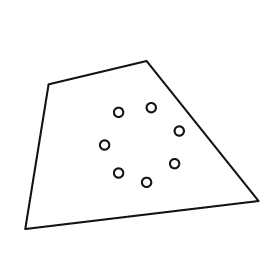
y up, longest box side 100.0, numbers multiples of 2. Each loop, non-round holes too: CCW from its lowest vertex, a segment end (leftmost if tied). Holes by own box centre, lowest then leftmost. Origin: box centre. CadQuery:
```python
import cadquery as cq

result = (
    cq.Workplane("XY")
    .moveTo(-50.0, -36.0)
    .lineTo(50.0, -24.0)
    .lineTo(2.0, 36.0)
    .lineTo(-40.0, 26.0)
    .close()
    .moveTo(2.0, -16.0)
    .circle(2.0)
    .moveTo(-10.0, -12.0)
    .circle(2.0)
    .moveTo(14.0, -8.0)
    .circle(2.0)
    .moveTo(-16.0, 0.0)
    .circle(2.0)
    .moveTo(16.0, 6.0)
    .circle(2.0)
    .moveTo(-10.0, 14.0)
    .circle(2.0)
    .moveTo(4.0, 16.0)
    .circle(2.0)
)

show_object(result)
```